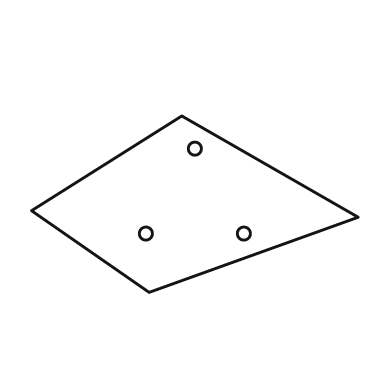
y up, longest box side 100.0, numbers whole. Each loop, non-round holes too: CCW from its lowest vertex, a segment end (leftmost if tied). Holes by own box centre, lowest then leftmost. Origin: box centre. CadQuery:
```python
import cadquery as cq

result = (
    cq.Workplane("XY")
    .moveTo(-14.0, -27.0)
    .lineTo(50.0, -4.0)
    .lineTo(-4.0, 27.0)
    .lineTo(-50.0, -2.0)
    .close()
    .moveTo(-15.0, -9.0)
    .circle(2.0)
    .moveTo(15.0, -9.0)
    .circle(2.0)
    .moveTo(0.0, 17.0)
    .circle(2.0)
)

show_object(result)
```